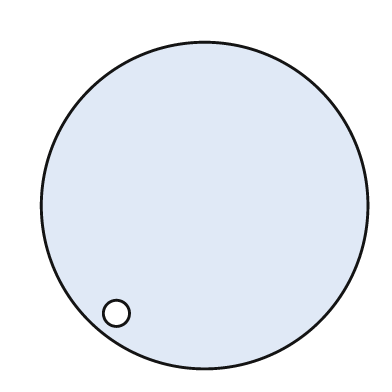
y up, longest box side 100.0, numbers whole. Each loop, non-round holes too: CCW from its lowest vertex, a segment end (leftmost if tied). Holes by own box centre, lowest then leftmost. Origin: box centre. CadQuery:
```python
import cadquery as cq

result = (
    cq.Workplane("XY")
    .moveTo(0.0, 0.0)
    .circle(50.0)
    .moveTo(-27.0, -33.0)
    .circle(4.0)
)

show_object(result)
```